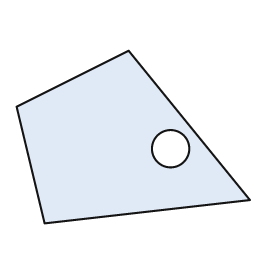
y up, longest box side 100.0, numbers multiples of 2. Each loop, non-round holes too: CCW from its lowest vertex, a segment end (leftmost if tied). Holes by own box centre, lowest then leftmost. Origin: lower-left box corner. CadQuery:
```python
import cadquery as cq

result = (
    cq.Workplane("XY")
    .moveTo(12.0, 0.0)
    .lineTo(100.0, 10.0)
    .lineTo(48.0, 74.0)
    .lineTo(0.0, 50.0)
    .close()
    .moveTo(66.0, 32.0)
    .circle(8.0)
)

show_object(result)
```